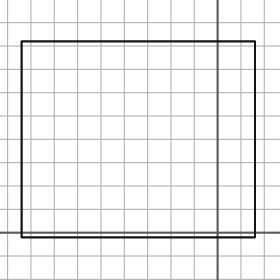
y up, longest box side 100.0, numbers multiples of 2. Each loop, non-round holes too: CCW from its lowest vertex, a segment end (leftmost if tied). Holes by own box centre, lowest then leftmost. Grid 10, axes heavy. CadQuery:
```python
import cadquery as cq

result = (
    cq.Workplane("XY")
    .moveTo(-84.0, -2.0)
    .lineTo(16.0, -2.0)
    .lineTo(16.0, 82.0)
    .lineTo(-84.0, 82.0)
    .close()
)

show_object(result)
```